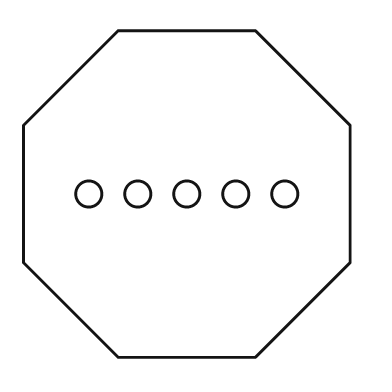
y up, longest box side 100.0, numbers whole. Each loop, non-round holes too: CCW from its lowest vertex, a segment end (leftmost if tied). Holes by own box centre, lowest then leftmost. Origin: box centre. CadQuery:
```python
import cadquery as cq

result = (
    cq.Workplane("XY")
    .moveTo(-21.0, -50.0)
    .lineTo(21.0, -50.0)
    .lineTo(50.0, -21.0)
    .lineTo(50.0, 21.0)
    .lineTo(21.0, 50.0)
    .lineTo(-21.0, 50.0)
    .lineTo(-50.0, 21.0)
    .lineTo(-50.0, -21.0)
    .close()
    .moveTo(-30.0, 0.0)
    .circle(4.0)
    .moveTo(-15.0, 0.0)
    .circle(4.0)
    .moveTo(0.0, 0.0)
    .circle(4.0)
    .moveTo(15.0, 0.0)
    .circle(4.0)
    .moveTo(30.0, 0.0)
    .circle(4.0)
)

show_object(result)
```